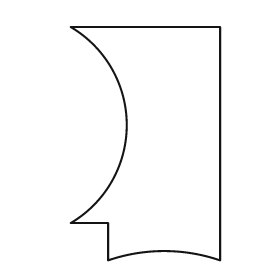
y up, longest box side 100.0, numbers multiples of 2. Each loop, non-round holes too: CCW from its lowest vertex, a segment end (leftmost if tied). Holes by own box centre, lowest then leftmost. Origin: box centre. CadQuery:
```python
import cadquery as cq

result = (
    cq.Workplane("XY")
    .moveTo(-16.0, -50.0)
    .threePointArc((8.0, -46.0), (32.0, -50.0))
    .lineTo(32.0, 50.0)
    .lineTo(-32.0, 50.0)
    .threePointArc((-8.0, 8.0), (-32.0, -34.0))
    .lineTo(-16.0, -34.0)
    .close()
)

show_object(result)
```